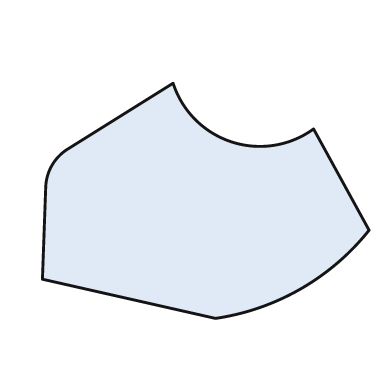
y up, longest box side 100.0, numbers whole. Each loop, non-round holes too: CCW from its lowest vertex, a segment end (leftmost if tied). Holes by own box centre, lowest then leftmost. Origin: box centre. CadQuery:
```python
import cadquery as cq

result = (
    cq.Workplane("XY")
    .moveTo(3.0, -36.0)
    .threePointArc((29.0, -27.0), (50.0, -9.0))
    .lineTo(33.0, 22.0)
    .threePointArc((8.0, 18.0), (-10.0, 36.0))
    .lineTo(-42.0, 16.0)
    .threePointArc((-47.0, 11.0), (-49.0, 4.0))
    .lineTo(-50.0, -24.0)
    .close()
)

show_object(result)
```